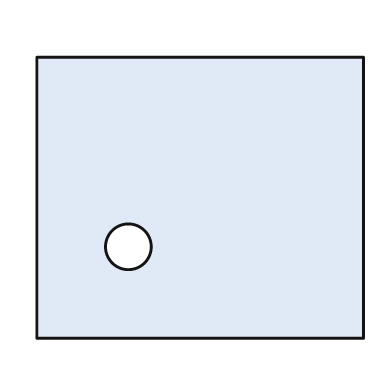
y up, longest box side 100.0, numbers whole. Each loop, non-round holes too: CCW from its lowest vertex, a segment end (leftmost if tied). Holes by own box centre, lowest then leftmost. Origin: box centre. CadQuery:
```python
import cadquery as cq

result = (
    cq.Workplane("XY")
    .moveTo(-50.0, -43.0)
    .lineTo(50.0, -43.0)
    .lineTo(50.0, 43.0)
    .lineTo(-50.0, 43.0)
    .close()
    .moveTo(-22.0, -15.0)
    .circle(7.0)
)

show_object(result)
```